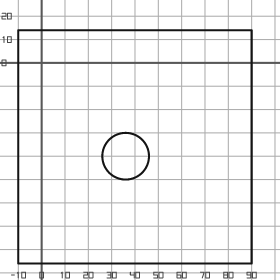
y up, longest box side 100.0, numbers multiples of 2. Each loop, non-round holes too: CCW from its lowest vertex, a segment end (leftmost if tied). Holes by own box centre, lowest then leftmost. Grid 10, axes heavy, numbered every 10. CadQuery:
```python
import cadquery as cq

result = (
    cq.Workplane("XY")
    .moveTo(-10.0, -86.0)
    .lineTo(90.0, -86.0)
    .lineTo(90.0, 14.0)
    .lineTo(-10.0, 14.0)
    .close()
    .moveTo(36.0, -40.0)
    .circle(10.0)
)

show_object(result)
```